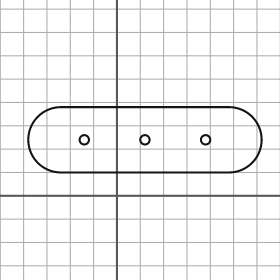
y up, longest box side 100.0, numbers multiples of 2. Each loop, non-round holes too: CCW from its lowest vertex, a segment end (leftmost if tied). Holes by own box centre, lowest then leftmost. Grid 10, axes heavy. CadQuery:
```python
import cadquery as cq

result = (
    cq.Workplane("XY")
    .moveTo(-24.0, 10.0)
    .lineTo(48.0, 10.0)
    .threePointArc((62.0, 24.0), (48.0, 38.0))
    .lineTo(-24.0, 38.0)
    .threePointArc((-38.0, 24.0), (-24.0, 10.0))
    .close()
    .moveTo(-14.0, 24.0)
    .circle(2.0)
    .moveTo(12.0, 24.0)
    .circle(2.0)
    .moveTo(38.0, 24.0)
    .circle(2.0)
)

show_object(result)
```